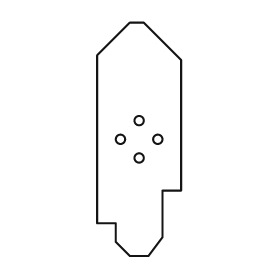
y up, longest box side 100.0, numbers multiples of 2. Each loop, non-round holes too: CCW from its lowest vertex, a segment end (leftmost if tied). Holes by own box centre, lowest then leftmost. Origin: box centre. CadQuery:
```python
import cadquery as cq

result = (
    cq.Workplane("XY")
    .moveTo(-4.0, -50.0)
    .lineTo(4.0, -50.0)
    .lineTo(10.0, -42.0)
    .lineTo(10.0, -22.0)
    .lineTo(18.0, -22.0)
    .lineTo(18.0, 34.0)
    .lineTo(2.0, 50.0)
    .lineTo(-4.0, 50.0)
    .lineTo(-18.0, 36.0)
    .lineTo(-18.0, -36.0)
    .lineTo(-10.0, -36.0)
    .lineTo(-10.0, -44.0)
    .close()
    .moveTo(0.0, -8.0)
    .circle(2.0)
    .moveTo(-8.0, 0.0)
    .circle(2.0)
    .moveTo(8.0, 0.0)
    .circle(2.0)
    .moveTo(0.0, 8.0)
    .circle(2.0)
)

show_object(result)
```